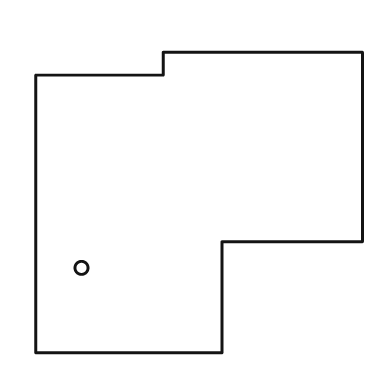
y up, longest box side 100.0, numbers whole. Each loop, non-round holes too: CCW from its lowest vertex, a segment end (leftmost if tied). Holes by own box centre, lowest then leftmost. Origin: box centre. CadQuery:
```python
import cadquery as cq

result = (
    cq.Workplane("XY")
    .moveTo(-50.0, -46.0)
    .lineTo(7.0, -46.0)
    .lineTo(7.0, -12.0)
    .lineTo(50.0, -12.0)
    .lineTo(50.0, 46.0)
    .lineTo(-11.0, 46.0)
    .lineTo(-11.0, 39.0)
    .lineTo(-50.0, 39.0)
    .close()
    .moveTo(-36.0, -20.0)
    .circle(2.0)
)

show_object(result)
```